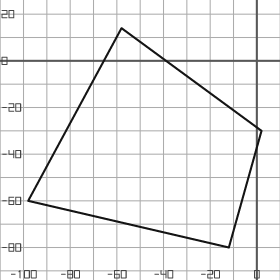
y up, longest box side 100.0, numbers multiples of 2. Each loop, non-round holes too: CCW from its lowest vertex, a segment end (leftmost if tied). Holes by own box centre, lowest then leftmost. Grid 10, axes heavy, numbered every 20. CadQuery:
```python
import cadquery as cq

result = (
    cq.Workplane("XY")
    .moveTo(-12.0, -80.0)
    .lineTo(2.0, -30.0)
    .lineTo(-58.0, 14.0)
    .lineTo(-98.0, -60.0)
    .close()
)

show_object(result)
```